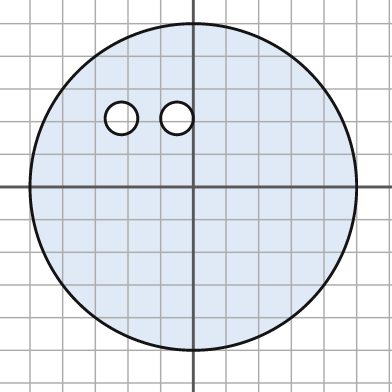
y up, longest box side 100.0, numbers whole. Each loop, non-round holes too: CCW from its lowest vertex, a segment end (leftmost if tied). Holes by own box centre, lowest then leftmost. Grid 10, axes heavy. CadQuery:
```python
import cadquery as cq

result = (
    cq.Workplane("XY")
    .moveTo(0.0, 0.0)
    .circle(50.0)
    .moveTo(-22.0, 21.0)
    .circle(5.0)
    .moveTo(-5.0, 21.0)
    .circle(5.0)
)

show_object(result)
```